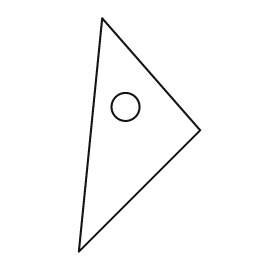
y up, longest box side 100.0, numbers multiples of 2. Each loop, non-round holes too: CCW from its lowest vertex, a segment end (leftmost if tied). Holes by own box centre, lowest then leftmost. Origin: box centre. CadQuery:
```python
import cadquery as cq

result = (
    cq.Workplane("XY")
    .moveTo(-26.0, -50.0)
    .lineTo(26.0, 2.0)
    .lineTo(-16.0, 50.0)
    .close()
    .moveTo(-6.0, 12.0)
    .circle(6.0)
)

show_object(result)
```